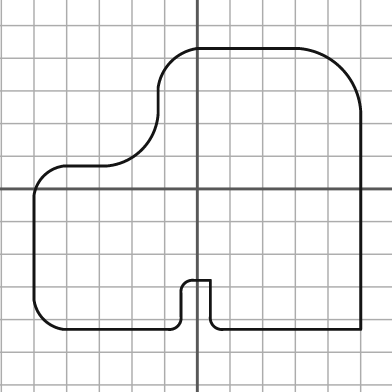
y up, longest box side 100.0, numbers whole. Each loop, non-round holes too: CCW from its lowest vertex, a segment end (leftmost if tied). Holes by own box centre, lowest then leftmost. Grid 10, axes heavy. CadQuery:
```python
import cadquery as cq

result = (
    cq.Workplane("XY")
    .moveTo(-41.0, -43.0)
    .lineTo(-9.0, -43.0)
    .threePointArc((-6.0, -42.0), (-5.0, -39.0))
    .lineTo(-5.0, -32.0)
    .threePointArc((-4.0, -29.0), (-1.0, -28.0))
    .lineTo(4.0, -28.0)
    .lineTo(4.0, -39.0)
    .threePointArc((5.0, -42.0), (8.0, -43.0))
    .lineTo(50.0, -43.0)
    .lineTo(50.0, 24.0)
    .threePointArc((44.0, 37.0), (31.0, 43.0))
    .lineTo(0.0, 43.0)
    .threePointArc((-8.0, 39.0), (-12.0, 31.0))
    .lineTo(-12.0, 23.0)
    .threePointArc((-17.0, 12.0), (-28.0, 7.0))
    .lineTo(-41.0, 7.0)
    .threePointArc((-47.0, 4.0), (-50.0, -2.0))
    .lineTo(-50.0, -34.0)
    .threePointArc((-47.0, -40.0), (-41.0, -43.0))
    .close()
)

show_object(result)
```